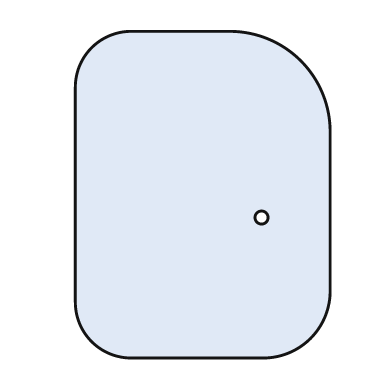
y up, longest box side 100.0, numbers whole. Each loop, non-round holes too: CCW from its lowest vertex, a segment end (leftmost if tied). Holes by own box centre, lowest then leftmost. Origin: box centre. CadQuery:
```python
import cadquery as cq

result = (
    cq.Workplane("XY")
    .moveTo(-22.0, -50.0)
    .lineTo(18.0, -50.0)
    .threePointArc((33.0, -44.0), (39.0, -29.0))
    .lineTo(39.0, 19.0)
    .threePointArc((30.0, 41.0), (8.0, 50.0))
    .lineTo(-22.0, 50.0)
    .threePointArc((-34.0, 45.0), (-39.0, 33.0))
    .lineTo(-39.0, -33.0)
    .threePointArc((-34.0, -45.0), (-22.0, -50.0))
    .close()
    .moveTo(18.0, -7.0)
    .circle(2.0)
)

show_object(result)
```